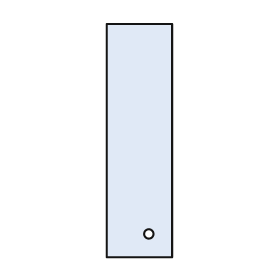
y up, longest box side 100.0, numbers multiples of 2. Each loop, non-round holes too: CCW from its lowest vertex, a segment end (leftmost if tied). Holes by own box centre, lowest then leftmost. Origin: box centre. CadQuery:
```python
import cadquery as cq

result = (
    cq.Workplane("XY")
    .moveTo(-14.0, -50.0)
    .lineTo(14.0, -50.0)
    .lineTo(14.0, 50.0)
    .lineTo(-14.0, 50.0)
    .close()
    .moveTo(4.0, -40.0)
    .circle(2.0)
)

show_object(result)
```